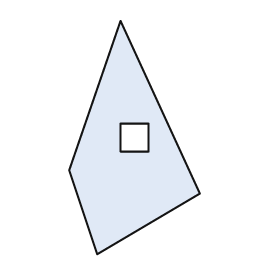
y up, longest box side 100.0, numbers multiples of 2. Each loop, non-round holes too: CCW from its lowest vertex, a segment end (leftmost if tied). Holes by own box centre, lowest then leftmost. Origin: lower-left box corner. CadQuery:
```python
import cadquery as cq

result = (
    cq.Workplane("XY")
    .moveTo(12.0, 0.0)
    .lineTo(56.0, 26.0)
    .lineTo(22.0, 100.0)
    .lineTo(0.0, 36.0)
    .close()
    .moveTo(22.0, 44.0)
    .lineTo(34.0, 44.0)
    .lineTo(34.0, 56.0)
    .lineTo(22.0, 56.0)
    .close()
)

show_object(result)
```